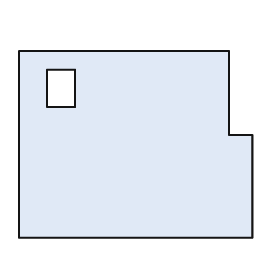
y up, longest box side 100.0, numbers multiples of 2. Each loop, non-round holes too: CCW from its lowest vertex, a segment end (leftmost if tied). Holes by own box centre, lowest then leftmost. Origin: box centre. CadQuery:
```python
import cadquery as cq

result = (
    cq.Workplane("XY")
    .moveTo(-50.0, -40.0)
    .lineTo(50.0, -40.0)
    .lineTo(50.0, 4.0)
    .lineTo(40.0, 4.0)
    .lineTo(40.0, 40.0)
    .lineTo(-50.0, 40.0)
    .close()
    .moveTo(-38.0, 16.0)
    .lineTo(-26.0, 16.0)
    .lineTo(-26.0, 32.0)
    .lineTo(-38.0, 32.0)
    .close()
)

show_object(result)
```